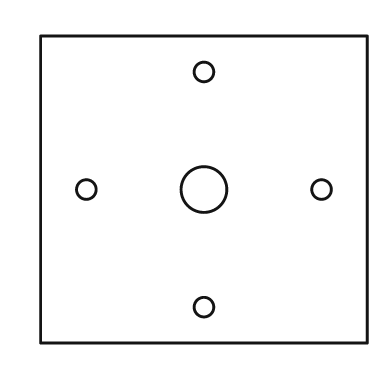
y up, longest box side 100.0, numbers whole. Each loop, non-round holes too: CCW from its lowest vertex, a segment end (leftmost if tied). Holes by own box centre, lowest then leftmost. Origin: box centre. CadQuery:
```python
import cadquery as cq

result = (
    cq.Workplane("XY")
    .moveTo(-50.0, -47.0)
    .lineTo(50.0, -47.0)
    .lineTo(50.0, 47.0)
    .lineTo(-50.0, 47.0)
    .close()
    .moveTo(0.0, -36.0)
    .circle(3.0)
    .moveTo(-36.0, 0.0)
    .circle(3.0)
    .moveTo(0.0, 0.0)
    .circle(7.0)
    .moveTo(36.0, 0.0)
    .circle(3.0)
    .moveTo(0.0, 36.0)
    .circle(3.0)
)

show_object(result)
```